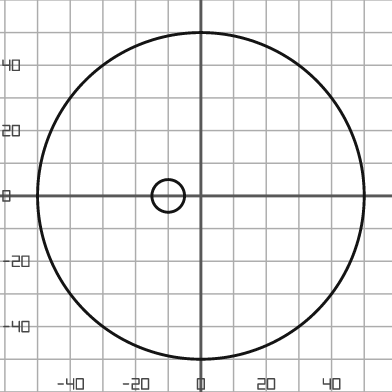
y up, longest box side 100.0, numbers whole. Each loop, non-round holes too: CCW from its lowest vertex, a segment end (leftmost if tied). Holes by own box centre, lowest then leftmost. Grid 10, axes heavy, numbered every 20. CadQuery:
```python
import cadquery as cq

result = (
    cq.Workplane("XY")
    .moveTo(0.0, 0.0)
    .circle(50.0)
    .moveTo(-10.0, 0.0)
    .circle(5.0)
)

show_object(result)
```